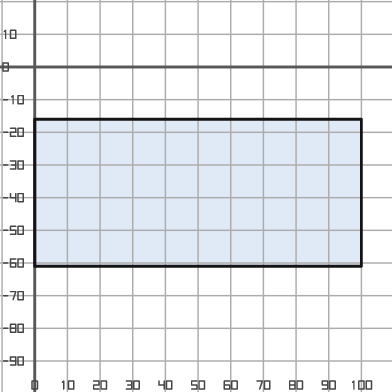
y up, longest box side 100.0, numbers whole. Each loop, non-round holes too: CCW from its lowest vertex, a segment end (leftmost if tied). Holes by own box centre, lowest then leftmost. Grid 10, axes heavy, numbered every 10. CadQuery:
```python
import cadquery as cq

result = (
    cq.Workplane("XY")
    .moveTo(0.0, -61.0)
    .lineTo(100.0, -61.0)
    .lineTo(100.0, -16.0)
    .lineTo(0.0, -16.0)
    .close()
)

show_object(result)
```